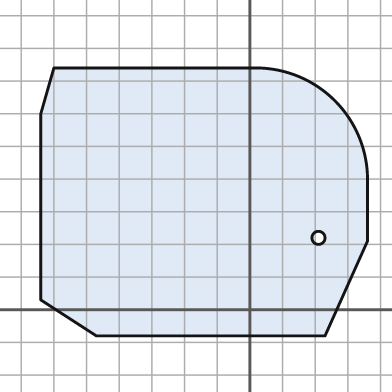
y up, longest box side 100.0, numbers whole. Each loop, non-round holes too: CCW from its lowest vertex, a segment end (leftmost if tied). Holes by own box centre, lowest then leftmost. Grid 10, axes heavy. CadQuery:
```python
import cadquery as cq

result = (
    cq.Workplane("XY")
    .moveTo(-47.0, -8.0)
    .lineTo(23.0, -8.0)
    .lineTo(36.0, 21.0)
    .lineTo(36.0, 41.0)
    .threePointArc((26.0, 64.0), (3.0, 74.0))
    .lineTo(-60.0, 74.0)
    .lineTo(-64.0, 60.0)
    .lineTo(-64.0, 3.0)
    .close()
    .moveTo(21.0, 22.0)
    .circle(2.0)
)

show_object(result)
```